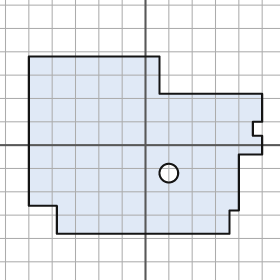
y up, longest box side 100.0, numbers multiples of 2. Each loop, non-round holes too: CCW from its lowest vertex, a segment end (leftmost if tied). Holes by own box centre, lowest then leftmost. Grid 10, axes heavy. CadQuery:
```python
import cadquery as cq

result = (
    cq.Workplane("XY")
    .moveTo(-38.0, -38.0)
    .lineTo(36.0, -38.0)
    .lineTo(36.0, -28.0)
    .lineTo(40.0, -28.0)
    .lineTo(40.0, -4.0)
    .lineTo(50.0, -4.0)
    .lineTo(50.0, 4.0)
    .lineTo(46.0, 4.0)
    .lineTo(46.0, 10.0)
    .lineTo(50.0, 10.0)
    .lineTo(50.0, 22.0)
    .lineTo(6.0, 22.0)
    .lineTo(6.0, 38.0)
    .lineTo(-50.0, 38.0)
    .lineTo(-50.0, -26.0)
    .lineTo(-38.0, -26.0)
    .close()
    .moveTo(10.0, -12.0)
    .circle(4.0)
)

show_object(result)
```